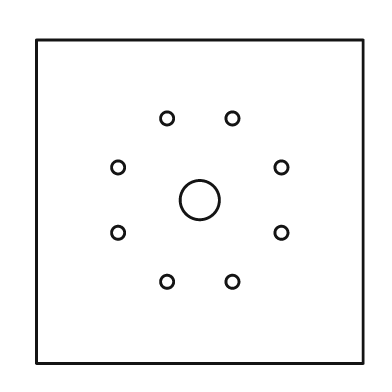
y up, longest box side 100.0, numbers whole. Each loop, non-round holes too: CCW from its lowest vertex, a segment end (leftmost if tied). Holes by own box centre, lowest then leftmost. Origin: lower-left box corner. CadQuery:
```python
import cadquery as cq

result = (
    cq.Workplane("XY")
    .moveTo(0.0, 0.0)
    .lineTo(100.0, 0.0)
    .lineTo(100.0, 99.0)
    .lineTo(0.0, 99.0)
    .close()
    .moveTo(40.0, 25.0)
    .circle(2.0)
    .moveTo(60.0, 25.0)
    .circle(2.0)
    .moveTo(25.0, 40.0)
    .circle(2.0)
    .moveTo(75.0, 40.0)
    .circle(2.0)
    .moveTo(50.0, 50.0)
    .circle(6.0)
    .moveTo(25.0, 60.0)
    .circle(2.0)
    .moveTo(75.0, 60.0)
    .circle(2.0)
    .moveTo(40.0, 75.0)
    .circle(2.0)
    .moveTo(60.0, 75.0)
    .circle(2.0)
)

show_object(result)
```